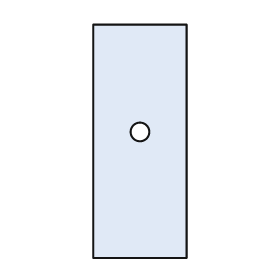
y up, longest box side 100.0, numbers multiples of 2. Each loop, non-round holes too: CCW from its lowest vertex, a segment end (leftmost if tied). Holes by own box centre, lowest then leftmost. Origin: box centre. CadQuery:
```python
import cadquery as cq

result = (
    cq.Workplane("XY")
    .moveTo(-20.0, -50.0)
    .lineTo(20.0, -50.0)
    .lineTo(20.0, 50.0)
    .lineTo(-20.0, 50.0)
    .close()
    .moveTo(0.0, 4.0)
    .circle(4.0)
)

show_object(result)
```